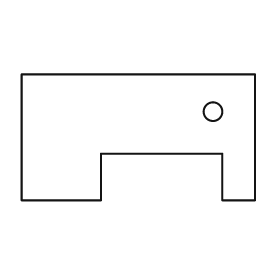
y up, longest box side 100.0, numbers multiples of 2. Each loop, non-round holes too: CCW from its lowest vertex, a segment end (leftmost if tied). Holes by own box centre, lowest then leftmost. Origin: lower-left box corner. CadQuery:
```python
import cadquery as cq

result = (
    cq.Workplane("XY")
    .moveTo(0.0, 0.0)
    .lineTo(34.0, 0.0)
    .lineTo(34.0, 20.0)
    .lineTo(86.0, 20.0)
    .lineTo(86.0, 0.0)
    .lineTo(100.0, 0.0)
    .lineTo(100.0, 54.0)
    .lineTo(0.0, 54.0)
    .close()
    .moveTo(82.0, 38.0)
    .circle(4.0)
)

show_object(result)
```